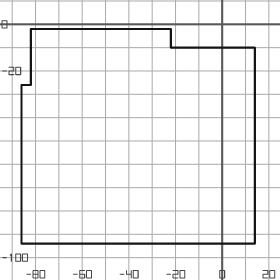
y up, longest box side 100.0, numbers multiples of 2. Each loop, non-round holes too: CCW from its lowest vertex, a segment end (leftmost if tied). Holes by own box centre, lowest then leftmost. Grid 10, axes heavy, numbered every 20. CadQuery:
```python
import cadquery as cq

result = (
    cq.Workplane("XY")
    .moveTo(-86.0, -94.0)
    .lineTo(14.0, -94.0)
    .lineTo(14.0, -10.0)
    .lineTo(-22.0, -10.0)
    .lineTo(-22.0, -2.0)
    .lineTo(-82.0, -2.0)
    .lineTo(-82.0, -26.0)
    .lineTo(-86.0, -26.0)
    .close()
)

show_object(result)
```